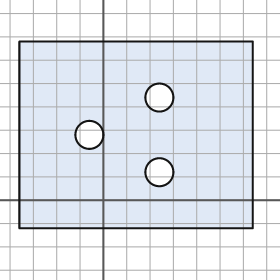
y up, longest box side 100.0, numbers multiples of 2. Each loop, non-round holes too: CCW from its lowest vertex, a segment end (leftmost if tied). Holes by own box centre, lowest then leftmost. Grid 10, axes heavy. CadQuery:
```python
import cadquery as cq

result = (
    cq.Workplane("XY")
    .moveTo(-36.0, -12.0)
    .lineTo(64.0, -12.0)
    .lineTo(64.0, 68.0)
    .lineTo(-36.0, 68.0)
    .close()
    .moveTo(24.0, 12.0)
    .circle(6.0)
    .moveTo(-6.0, 28.0)
    .circle(6.0)
    .moveTo(24.0, 44.0)
    .circle(6.0)
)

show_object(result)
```